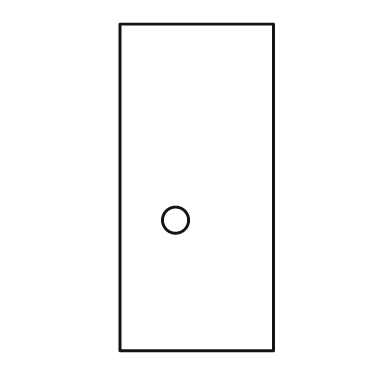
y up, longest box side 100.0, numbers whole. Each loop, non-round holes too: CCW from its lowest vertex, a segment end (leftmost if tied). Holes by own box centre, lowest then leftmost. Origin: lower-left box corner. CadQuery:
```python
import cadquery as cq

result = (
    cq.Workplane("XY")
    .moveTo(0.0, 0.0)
    .lineTo(47.0, 0.0)
    .lineTo(47.0, 100.0)
    .lineTo(0.0, 100.0)
    .close()
    .moveTo(17.0, 40.0)
    .circle(4.0)
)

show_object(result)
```